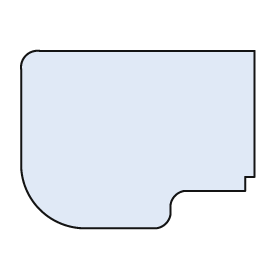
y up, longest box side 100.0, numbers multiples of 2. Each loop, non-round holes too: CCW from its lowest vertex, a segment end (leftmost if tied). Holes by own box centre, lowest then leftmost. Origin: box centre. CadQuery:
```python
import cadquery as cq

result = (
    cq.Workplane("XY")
    .moveTo(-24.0, -38.0)
    .lineTo(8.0, -38.0)
    .threePointArc((12.0, -36.0), (14.0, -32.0))
    .lineTo(14.0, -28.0)
    .threePointArc((16.0, -24.0), (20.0, -22.0))
    .lineTo(46.0, -22.0)
    .lineTo(46.0, -16.0)
    .lineTo(50.0, -16.0)
    .lineTo(50.0, 38.0)
    .lineTo(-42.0, 38.0)
    .threePointArc((-48.0, 36.0), (-50.0, 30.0))
    .lineTo(-50.0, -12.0)
    .threePointArc((-42.0, -30.0), (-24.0, -38.0))
    .close()
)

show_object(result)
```